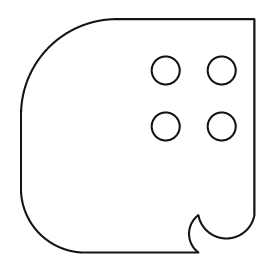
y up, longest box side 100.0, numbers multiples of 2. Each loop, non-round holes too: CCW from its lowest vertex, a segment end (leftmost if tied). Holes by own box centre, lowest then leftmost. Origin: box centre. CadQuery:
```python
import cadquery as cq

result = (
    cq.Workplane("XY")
    .moveTo(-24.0, -50.0)
    .lineTo(26.0, -50.0)
    .threePointArc((22.0, -42.0), (26.0, -34.0))
    .threePointArc((38.0, -44.0), (50.0, -34.0))
    .lineTo(50.0, 50.0)
    .lineTo(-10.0, 50.0)
    .threePointArc((-38.0, 38.0), (-50.0, 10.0))
    .lineTo(-50.0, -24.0)
    .threePointArc((-42.0, -42.0), (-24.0, -50.0))
    .close()
    .moveTo(12.0, 4.0)
    .circle(6.0)
    .moveTo(36.0, 4.0)
    .circle(6.0)
    .moveTo(12.0, 28.0)
    .circle(6.0)
    .moveTo(36.0, 28.0)
    .circle(6.0)
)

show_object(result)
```